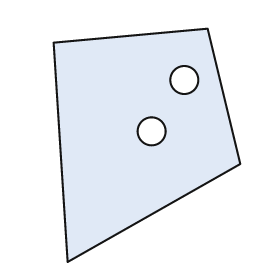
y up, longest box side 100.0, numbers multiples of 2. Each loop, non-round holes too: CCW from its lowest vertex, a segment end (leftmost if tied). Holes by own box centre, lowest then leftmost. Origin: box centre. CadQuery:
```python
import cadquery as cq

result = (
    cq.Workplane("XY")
    .moveTo(-34.0, -50.0)
    .lineTo(40.0, -8.0)
    .lineTo(26.0, 50.0)
    .lineTo(-40.0, 44.0)
    .close()
    .moveTo(2.0, 6.0)
    .circle(6.0)
    .moveTo(16.0, 28.0)
    .circle(6.0)
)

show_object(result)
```